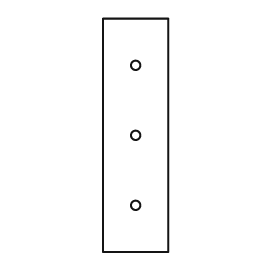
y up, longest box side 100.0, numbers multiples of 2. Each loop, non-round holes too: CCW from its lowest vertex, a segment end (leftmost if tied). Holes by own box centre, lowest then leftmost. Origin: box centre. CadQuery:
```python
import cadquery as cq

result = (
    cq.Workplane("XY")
    .moveTo(-14.0, -50.0)
    .lineTo(14.0, -50.0)
    .lineTo(14.0, 50.0)
    .lineTo(-14.0, 50.0)
    .close()
    .moveTo(0.0, -30.0)
    .circle(2.0)
    .moveTo(0.0, 0.0)
    .circle(2.0)
    .moveTo(0.0, 30.0)
    .circle(2.0)
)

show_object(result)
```